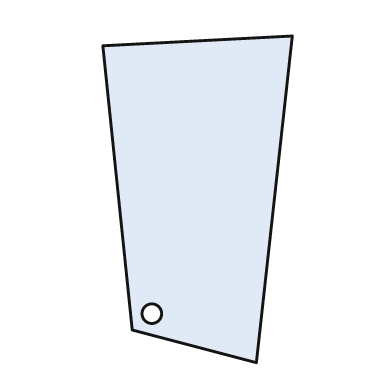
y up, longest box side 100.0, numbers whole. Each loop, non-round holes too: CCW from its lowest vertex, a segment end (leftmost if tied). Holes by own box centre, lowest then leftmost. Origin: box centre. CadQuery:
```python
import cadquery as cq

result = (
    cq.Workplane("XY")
    .moveTo(18.0, -50.0)
    .lineTo(29.0, 50.0)
    .lineTo(-29.0, 47.0)
    .lineTo(-20.0, -40.0)
    .close()
    .moveTo(-14.0, -35.0)
    .circle(3.0)
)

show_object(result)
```